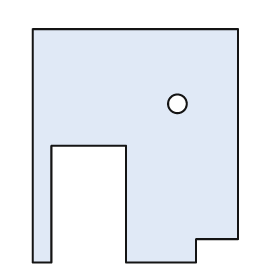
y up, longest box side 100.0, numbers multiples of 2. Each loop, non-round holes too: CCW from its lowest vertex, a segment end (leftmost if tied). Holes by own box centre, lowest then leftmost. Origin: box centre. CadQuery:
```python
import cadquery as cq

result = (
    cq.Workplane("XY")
    .moveTo(-44.0, -50.0)
    .lineTo(-36.0, -50.0)
    .lineTo(-36.0, 0.0)
    .lineTo(-4.0, 0.0)
    .lineTo(-4.0, -50.0)
    .lineTo(26.0, -50.0)
    .lineTo(26.0, -40.0)
    .lineTo(44.0, -40.0)
    .lineTo(44.0, 50.0)
    .lineTo(-44.0, 50.0)
    .close()
    .moveTo(18.0, 18.0)
    .circle(4.0)
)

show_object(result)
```